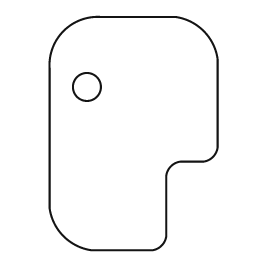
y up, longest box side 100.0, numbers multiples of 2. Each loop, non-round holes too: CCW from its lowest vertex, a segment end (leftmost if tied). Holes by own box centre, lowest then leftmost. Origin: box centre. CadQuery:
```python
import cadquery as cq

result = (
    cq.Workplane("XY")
    .moveTo(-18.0, -50.0)
    .lineTo(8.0, -50.0)
    .threePointArc((12.0, -48.0), (14.0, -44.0))
    .lineTo(14.0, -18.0)
    .threePointArc((16.0, -14.0), (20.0, -12.0))
    .lineTo(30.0, -12.0)
    .threePointArc((34.0, -10.0), (36.0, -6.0))
    .lineTo(36.0, 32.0)
    .threePointArc((30.0, 44.0), (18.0, 50.0))
    .lineTo(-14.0, 50.0)
    .threePointArc((-30.0, 44.0), (-36.0, 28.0))
    .lineTo(-36.0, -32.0)
    .threePointArc((-30.0, -44.0), (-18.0, -50.0))
    .close()
    .moveTo(-20.0, 20.0)
    .circle(6.0)
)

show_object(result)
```